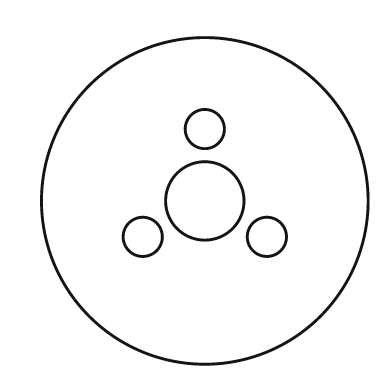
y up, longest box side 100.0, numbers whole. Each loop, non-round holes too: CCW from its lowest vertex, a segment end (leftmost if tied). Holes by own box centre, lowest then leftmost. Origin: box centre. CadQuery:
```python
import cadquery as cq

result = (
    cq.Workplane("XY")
    .moveTo(0.0, 0.0)
    .circle(50.0)
    .moveTo(-19.0, -11.0)
    .circle(6.0)
    .moveTo(19.0, -11.0)
    .circle(6.0)
    .moveTo(0.0, 0.0)
    .circle(12.0)
    .moveTo(0.0, 22.0)
    .circle(6.0)
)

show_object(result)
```